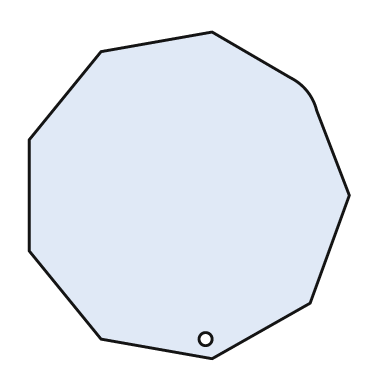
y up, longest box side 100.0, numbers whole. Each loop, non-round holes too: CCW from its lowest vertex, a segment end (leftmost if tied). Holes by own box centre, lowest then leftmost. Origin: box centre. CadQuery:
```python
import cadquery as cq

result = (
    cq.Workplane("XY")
    .moveTo(7.0, -50.0)
    .lineTo(37.0, -33.0)
    .lineTo(49.0, 0.0)
    .lineTo(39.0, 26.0)
    .threePointArc((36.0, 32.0), (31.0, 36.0))
    .lineTo(7.0, 50.0)
    .lineTo(-27.0, 44.0)
    .lineTo(-49.0, 17.0)
    .lineTo(-49.0, -17.0)
    .lineTo(-27.0, -44.0)
    .close()
    .moveTo(5.0, -44.0)
    .circle(2.0)
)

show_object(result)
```